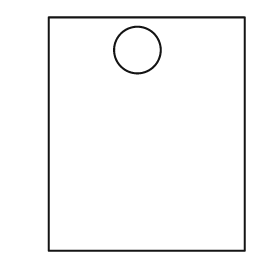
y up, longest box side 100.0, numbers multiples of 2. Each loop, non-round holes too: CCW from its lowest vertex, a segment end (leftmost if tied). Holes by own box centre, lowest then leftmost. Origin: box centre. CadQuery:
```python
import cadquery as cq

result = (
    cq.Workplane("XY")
    .moveTo(-42.0, -50.0)
    .lineTo(42.0, -50.0)
    .lineTo(42.0, 50.0)
    .lineTo(-42.0, 50.0)
    .close()
    .moveTo(-4.0, 36.0)
    .circle(10.0)
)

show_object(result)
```